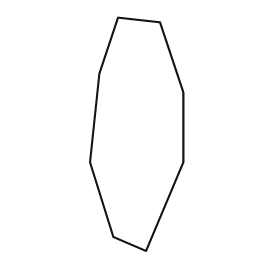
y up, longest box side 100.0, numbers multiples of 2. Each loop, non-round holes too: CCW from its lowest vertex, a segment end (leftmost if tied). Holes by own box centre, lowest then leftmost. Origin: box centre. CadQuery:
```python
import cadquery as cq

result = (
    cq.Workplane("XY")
    .moveTo(4.0, -50.0)
    .lineTo(20.0, -12.0)
    .lineTo(20.0, 18.0)
    .lineTo(10.0, 48.0)
    .lineTo(-8.0, 50.0)
    .lineTo(-16.0, 26.0)
    .lineTo(-20.0, -12.0)
    .lineTo(-10.0, -44.0)
    .close()
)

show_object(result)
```